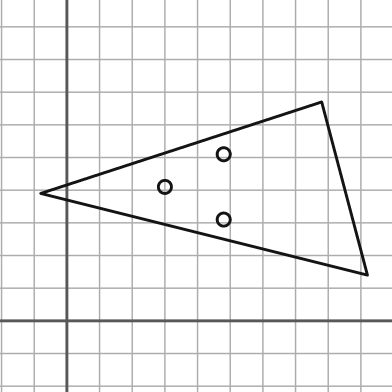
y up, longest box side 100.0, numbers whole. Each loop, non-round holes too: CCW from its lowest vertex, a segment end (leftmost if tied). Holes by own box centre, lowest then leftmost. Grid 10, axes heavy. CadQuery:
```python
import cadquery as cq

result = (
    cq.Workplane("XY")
    .moveTo(92.0, 14.0)
    .lineTo(78.0, 67.0)
    .lineTo(-8.0, 39.0)
    .close()
    .moveTo(48.0, 31.0)
    .circle(2.0)
    .moveTo(30.0, 41.0)
    .circle(2.0)
    .moveTo(48.0, 51.0)
    .circle(2.0)
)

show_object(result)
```